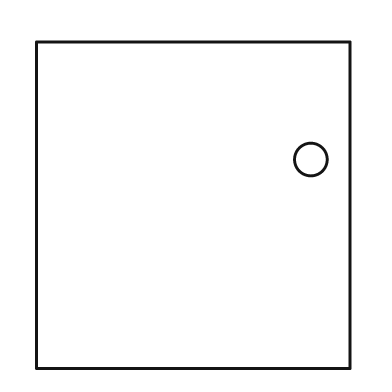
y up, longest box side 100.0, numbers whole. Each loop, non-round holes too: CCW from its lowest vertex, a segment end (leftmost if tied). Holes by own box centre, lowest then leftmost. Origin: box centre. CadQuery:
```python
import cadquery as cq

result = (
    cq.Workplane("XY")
    .moveTo(-48.0, -50.0)
    .lineTo(48.0, -50.0)
    .lineTo(48.0, 50.0)
    .lineTo(-48.0, 50.0)
    .close()
    .moveTo(36.0, 14.0)
    .circle(5.0)
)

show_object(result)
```